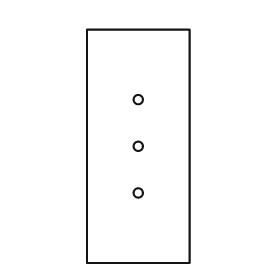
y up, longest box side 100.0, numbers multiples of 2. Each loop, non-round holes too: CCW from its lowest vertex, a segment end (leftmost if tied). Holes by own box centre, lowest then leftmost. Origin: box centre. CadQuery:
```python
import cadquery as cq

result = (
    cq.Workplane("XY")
    .moveTo(-22.0, -50.0)
    .lineTo(22.0, -50.0)
    .lineTo(22.0, 50.0)
    .lineTo(-22.0, 50.0)
    .close()
    .moveTo(0.0, -20.0)
    .circle(2.0)
    .moveTo(0.0, 0.0)
    .circle(2.0)
    .moveTo(0.0, 20.0)
    .circle(2.0)
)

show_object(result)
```